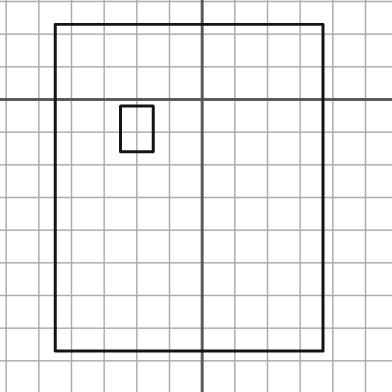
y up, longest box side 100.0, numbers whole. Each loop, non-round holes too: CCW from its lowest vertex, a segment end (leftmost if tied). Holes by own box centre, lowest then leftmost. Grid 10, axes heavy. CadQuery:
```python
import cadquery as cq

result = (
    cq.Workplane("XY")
    .moveTo(-45.0, -77.0)
    .lineTo(37.0, -77.0)
    .lineTo(37.0, 23.0)
    .lineTo(-45.0, 23.0)
    .close()
    .moveTo(-25.0, -16.0)
    .lineTo(-15.0, -16.0)
    .lineTo(-15.0, -2.0)
    .lineTo(-25.0, -2.0)
    .close()
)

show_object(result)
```